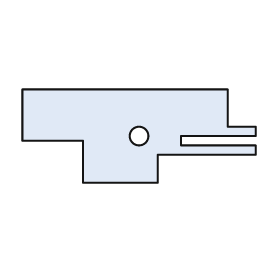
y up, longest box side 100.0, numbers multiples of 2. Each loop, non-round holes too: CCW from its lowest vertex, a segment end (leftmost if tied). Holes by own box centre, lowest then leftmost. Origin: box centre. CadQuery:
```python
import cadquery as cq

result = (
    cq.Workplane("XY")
    .moveTo(-24.0, -20.0)
    .lineTo(8.0, -20.0)
    .lineTo(8.0, -8.0)
    .lineTo(50.0, -8.0)
    .lineTo(50.0, -4.0)
    .lineTo(18.0, -4.0)
    .lineTo(18.0, 0.0)
    .lineTo(50.0, 0.0)
    .lineTo(50.0, 4.0)
    .lineTo(38.0, 4.0)
    .lineTo(38.0, 20.0)
    .lineTo(-50.0, 20.0)
    .lineTo(-50.0, -2.0)
    .lineTo(-24.0, -2.0)
    .close()
    .moveTo(0.0, 0.0)
    .circle(4.0)
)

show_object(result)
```